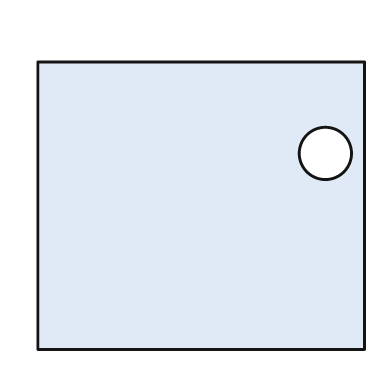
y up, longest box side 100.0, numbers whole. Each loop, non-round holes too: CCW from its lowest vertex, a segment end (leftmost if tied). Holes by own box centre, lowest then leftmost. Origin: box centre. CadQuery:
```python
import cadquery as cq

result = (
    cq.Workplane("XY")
    .moveTo(-50.0, -44.0)
    .lineTo(50.0, -44.0)
    .lineTo(50.0, 44.0)
    .lineTo(-50.0, 44.0)
    .close()
    .moveTo(38.0, 16.0)
    .circle(8.0)
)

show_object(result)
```